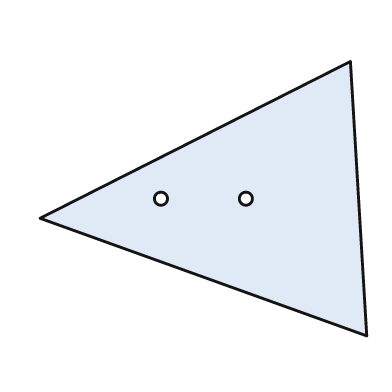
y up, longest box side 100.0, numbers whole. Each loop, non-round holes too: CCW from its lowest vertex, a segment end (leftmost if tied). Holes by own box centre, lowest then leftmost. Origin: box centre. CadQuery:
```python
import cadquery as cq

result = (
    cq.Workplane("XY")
    .moveTo(50.0, -42.0)
    .lineTo(45.0, 42.0)
    .lineTo(-50.0, -6.0)
    .close()
    .moveTo(-13.0, 0.0)
    .circle(2.0)
    .moveTo(13.0, 0.0)
    .circle(2.0)
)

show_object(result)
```